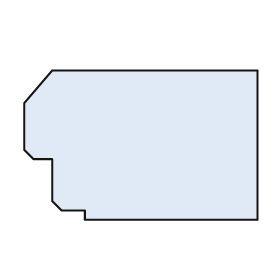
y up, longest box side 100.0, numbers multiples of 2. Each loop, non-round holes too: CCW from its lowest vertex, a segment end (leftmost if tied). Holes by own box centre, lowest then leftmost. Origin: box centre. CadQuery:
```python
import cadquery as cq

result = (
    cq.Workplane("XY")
    .moveTo(-24.0, -32.0)
    .lineTo(50.0, -32.0)
    .lineTo(50.0, 32.0)
    .lineTo(-38.0, 32.0)
    .lineTo(-50.0, 18.0)
    .lineTo(-50.0, -2.0)
    .lineTo(-46.0, -6.0)
    .lineTo(-38.0, -6.0)
    .lineTo(-38.0, -24.0)
    .lineTo(-34.0, -28.0)
    .lineTo(-24.0, -28.0)
    .close()
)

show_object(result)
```